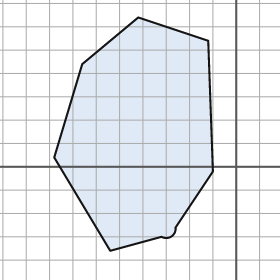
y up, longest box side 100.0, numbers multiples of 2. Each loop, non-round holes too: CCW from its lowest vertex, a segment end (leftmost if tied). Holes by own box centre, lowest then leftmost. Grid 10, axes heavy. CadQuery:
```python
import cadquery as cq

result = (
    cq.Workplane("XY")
    .moveTo(-54.0, -36.0)
    .lineTo(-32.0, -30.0)
    .threePointArc((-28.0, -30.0), (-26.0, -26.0))
    .lineTo(-10.0, -2.0)
    .lineTo(-12.0, 54.0)
    .lineTo(-42.0, 64.0)
    .lineTo(-66.0, 44.0)
    .lineTo(-78.0, 4.0)
    .close()
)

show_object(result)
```